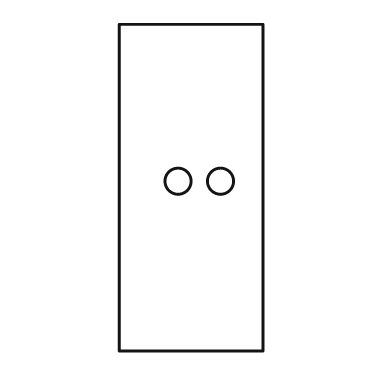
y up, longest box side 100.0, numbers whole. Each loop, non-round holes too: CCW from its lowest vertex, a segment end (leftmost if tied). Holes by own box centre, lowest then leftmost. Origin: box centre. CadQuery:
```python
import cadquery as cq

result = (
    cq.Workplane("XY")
    .moveTo(-22.0, -50.0)
    .lineTo(22.0, -50.0)
    .lineTo(22.0, 50.0)
    .lineTo(-22.0, 50.0)
    .close()
    .moveTo(-4.0, 2.0)
    .circle(4.0)
    .moveTo(9.0, 2.0)
    .circle(4.0)
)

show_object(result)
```